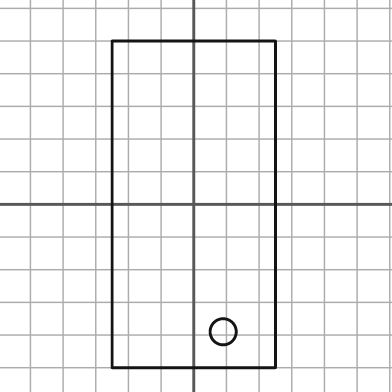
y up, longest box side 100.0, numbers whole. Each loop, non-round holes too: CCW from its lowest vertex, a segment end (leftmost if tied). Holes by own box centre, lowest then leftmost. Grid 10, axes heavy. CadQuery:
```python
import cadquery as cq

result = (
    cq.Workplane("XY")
    .moveTo(-25.0, -50.0)
    .lineTo(25.0, -50.0)
    .lineTo(25.0, 50.0)
    .lineTo(-25.0, 50.0)
    .close()
    .moveTo(9.0, -39.0)
    .circle(4.0)
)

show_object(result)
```